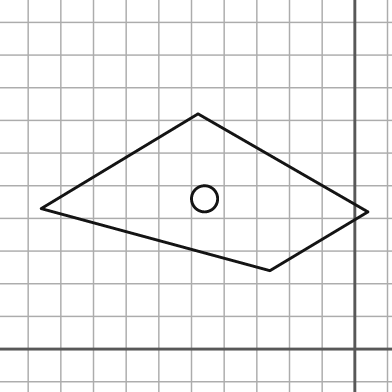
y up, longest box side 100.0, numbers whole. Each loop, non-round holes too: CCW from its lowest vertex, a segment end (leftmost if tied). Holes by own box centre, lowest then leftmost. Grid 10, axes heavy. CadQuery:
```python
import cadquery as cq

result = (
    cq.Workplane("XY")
    .moveTo(-26.0, 24.0)
    .lineTo(4.0, 42.0)
    .lineTo(-48.0, 72.0)
    .lineTo(-96.0, 43.0)
    .close()
    .moveTo(-46.0, 46.0)
    .circle(4.0)
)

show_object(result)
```